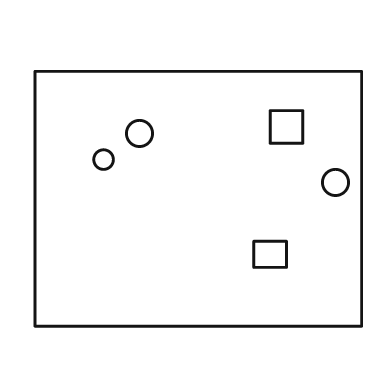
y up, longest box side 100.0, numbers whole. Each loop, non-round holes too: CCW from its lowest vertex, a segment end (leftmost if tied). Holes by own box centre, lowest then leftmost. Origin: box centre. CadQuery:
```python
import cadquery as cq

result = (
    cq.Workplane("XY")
    .moveTo(-50.0, -39.0)
    .lineTo(50.0, -39.0)
    .lineTo(50.0, 39.0)
    .lineTo(-50.0, 39.0)
    .close()
    .moveTo(17.0, -21.0)
    .lineTo(27.0, -21.0)
    .lineTo(27.0, -13.0)
    .lineTo(17.0, -13.0)
    .close()
    .moveTo(42.0, 5.0)
    .circle(4.0)
    .moveTo(-29.0, 12.0)
    .circle(3.0)
    .moveTo(-18.0, 20.0)
    .circle(4.0)
    .moveTo(22.0, 17.0)
    .lineTo(32.0, 17.0)
    .lineTo(32.0, 27.0)
    .lineTo(22.0, 27.0)
    .close()
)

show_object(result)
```